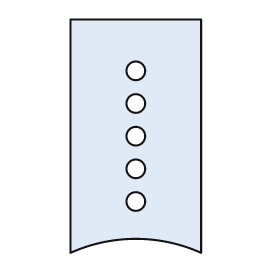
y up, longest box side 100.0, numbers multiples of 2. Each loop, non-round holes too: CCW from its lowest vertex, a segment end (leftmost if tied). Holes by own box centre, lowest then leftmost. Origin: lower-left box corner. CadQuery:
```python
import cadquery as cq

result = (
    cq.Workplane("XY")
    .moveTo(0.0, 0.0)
    .threePointArc((28.0, 6.0), (56.0, 0.0))
    .lineTo(56.0, 100.0)
    .lineTo(0.0, 100.0)
    .close()
    .moveTo(28.0, 22.0)
    .circle(4.0)
    .moveTo(28.0, 36.0)
    .circle(4.0)
    .moveTo(28.0, 50.0)
    .circle(4.0)
    .moveTo(28.0, 64.0)
    .circle(4.0)
    .moveTo(28.0, 78.0)
    .circle(4.0)
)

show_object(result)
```